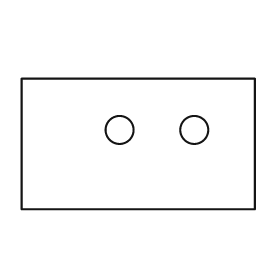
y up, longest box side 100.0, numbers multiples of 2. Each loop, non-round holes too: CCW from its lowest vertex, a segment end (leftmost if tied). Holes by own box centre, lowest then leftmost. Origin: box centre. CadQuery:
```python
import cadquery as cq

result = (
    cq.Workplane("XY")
    .moveTo(-50.0, -28.0)
    .lineTo(50.0, -28.0)
    .lineTo(50.0, 28.0)
    .lineTo(-50.0, 28.0)
    .close()
    .moveTo(-8.0, 6.0)
    .circle(6.0)
    .moveTo(24.0, 6.0)
    .circle(6.0)
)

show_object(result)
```